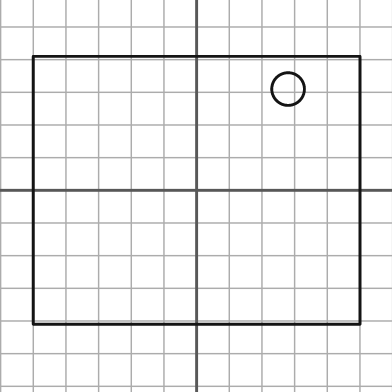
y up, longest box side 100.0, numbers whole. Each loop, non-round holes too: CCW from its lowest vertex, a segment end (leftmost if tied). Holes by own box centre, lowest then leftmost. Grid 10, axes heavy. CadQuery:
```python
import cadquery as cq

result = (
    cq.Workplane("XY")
    .moveTo(-50.0, -41.0)
    .lineTo(50.0, -41.0)
    .lineTo(50.0, 41.0)
    .lineTo(-50.0, 41.0)
    .close()
    .moveTo(28.0, 31.0)
    .circle(5.0)
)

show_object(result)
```